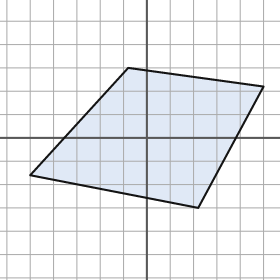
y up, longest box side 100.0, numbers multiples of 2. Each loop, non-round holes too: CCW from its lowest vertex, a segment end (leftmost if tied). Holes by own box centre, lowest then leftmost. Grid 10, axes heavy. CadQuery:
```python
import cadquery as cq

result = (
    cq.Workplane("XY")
    .moveTo(22.0, -30.0)
    .lineTo(50.0, 22.0)
    .lineTo(-8.0, 30.0)
    .lineTo(-50.0, -16.0)
    .close()
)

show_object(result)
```